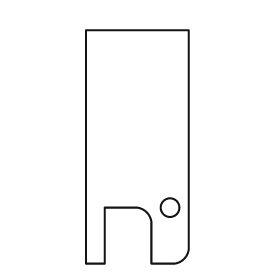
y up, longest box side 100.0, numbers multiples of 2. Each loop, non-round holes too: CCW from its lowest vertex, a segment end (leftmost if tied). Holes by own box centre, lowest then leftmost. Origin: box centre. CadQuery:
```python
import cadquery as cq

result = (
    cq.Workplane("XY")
    .moveTo(-22.0, -50.0)
    .lineTo(-14.0, -50.0)
    .lineTo(-14.0, -26.0)
    .lineTo(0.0, -26.0)
    .threePointArc((4.0, -28.0), (6.0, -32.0))
    .lineTo(6.0, -50.0)
    .lineTo(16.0, -50.0)
    .threePointArc((20.0, -48.0), (22.0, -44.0))
    .lineTo(22.0, 50.0)
    .lineTo(-22.0, 50.0)
    .close()
    .moveTo(14.0, -26.0)
    .circle(4.0)
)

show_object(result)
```